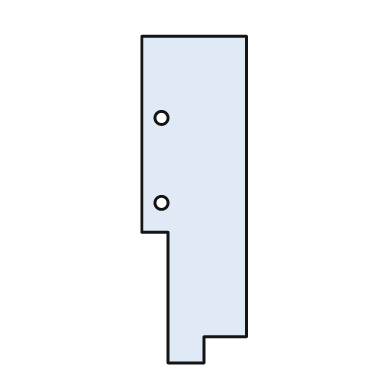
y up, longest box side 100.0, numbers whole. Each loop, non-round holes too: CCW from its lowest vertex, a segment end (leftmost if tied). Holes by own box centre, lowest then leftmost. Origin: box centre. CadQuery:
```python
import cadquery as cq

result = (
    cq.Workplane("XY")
    .moveTo(-8.0, -50.0)
    .lineTo(3.0, -50.0)
    .lineTo(3.0, -42.0)
    .lineTo(16.0, -42.0)
    .lineTo(16.0, 50.0)
    .lineTo(-16.0, 50.0)
    .lineTo(-16.0, -10.0)
    .lineTo(-8.0, -10.0)
    .close()
    .moveTo(-10.0, -1.0)
    .circle(2.0)
    .moveTo(-10.0, 25.0)
    .circle(2.0)
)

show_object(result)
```